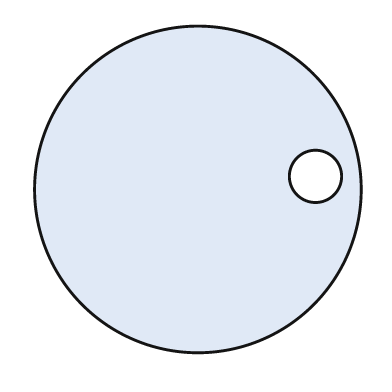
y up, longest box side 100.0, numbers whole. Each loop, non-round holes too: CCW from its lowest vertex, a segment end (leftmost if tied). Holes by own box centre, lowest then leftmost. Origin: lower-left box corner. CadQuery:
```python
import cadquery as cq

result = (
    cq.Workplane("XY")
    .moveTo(50.0, 50.0)
    .circle(50.0)
    .moveTo(86.0, 54.0)
    .circle(8.0)
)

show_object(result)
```